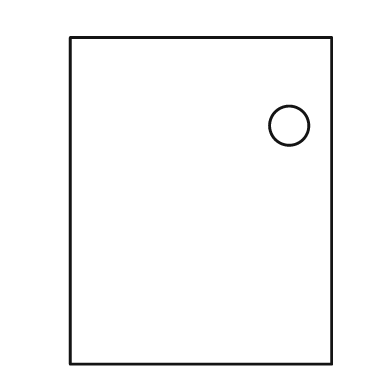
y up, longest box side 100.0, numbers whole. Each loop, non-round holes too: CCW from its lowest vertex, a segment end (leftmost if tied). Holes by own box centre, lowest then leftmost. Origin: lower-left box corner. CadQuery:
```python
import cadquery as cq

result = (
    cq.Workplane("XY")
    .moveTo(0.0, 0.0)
    .lineTo(80.0, 0.0)
    .lineTo(80.0, 100.0)
    .lineTo(0.0, 100.0)
    .close()
    .moveTo(67.0, 73.0)
    .circle(6.0)
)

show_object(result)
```